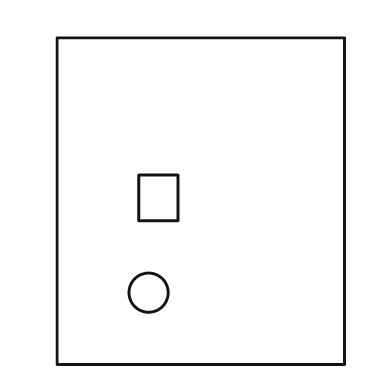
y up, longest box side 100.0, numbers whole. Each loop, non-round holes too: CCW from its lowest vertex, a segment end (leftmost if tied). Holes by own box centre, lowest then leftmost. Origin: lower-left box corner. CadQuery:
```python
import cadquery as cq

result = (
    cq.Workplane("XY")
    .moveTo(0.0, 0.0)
    .lineTo(88.0, 0.0)
    .lineTo(88.0, 100.0)
    .lineTo(0.0, 100.0)
    .close()
    .moveTo(28.0, 22.0)
    .circle(6.0)
    .moveTo(25.0, 44.0)
    .lineTo(37.0, 44.0)
    .lineTo(37.0, 58.0)
    .lineTo(25.0, 58.0)
    .close()
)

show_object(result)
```